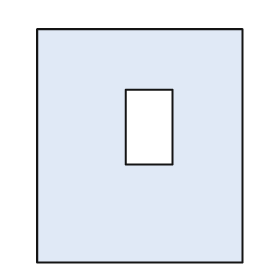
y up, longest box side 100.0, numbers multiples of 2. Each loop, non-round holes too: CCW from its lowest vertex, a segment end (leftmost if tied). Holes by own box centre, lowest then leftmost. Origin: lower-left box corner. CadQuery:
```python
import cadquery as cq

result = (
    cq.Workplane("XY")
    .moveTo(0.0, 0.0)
    .lineTo(88.0, 0.0)
    .lineTo(88.0, 100.0)
    .lineTo(0.0, 100.0)
    .close()
    .moveTo(38.0, 42.0)
    .lineTo(58.0, 42.0)
    .lineTo(58.0, 74.0)
    .lineTo(38.0, 74.0)
    .close()
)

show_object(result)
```